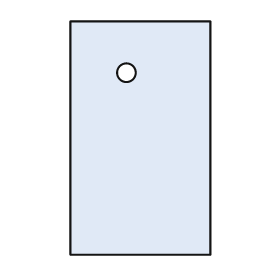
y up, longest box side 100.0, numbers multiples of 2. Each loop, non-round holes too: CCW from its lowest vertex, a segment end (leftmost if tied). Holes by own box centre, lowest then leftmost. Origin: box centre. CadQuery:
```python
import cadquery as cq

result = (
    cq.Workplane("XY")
    .moveTo(-30.0, -50.0)
    .lineTo(30.0, -50.0)
    .lineTo(30.0, 50.0)
    .lineTo(-30.0, 50.0)
    .close()
    .moveTo(-6.0, 28.0)
    .circle(4.0)
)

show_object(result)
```